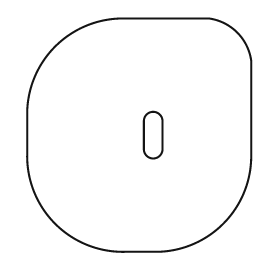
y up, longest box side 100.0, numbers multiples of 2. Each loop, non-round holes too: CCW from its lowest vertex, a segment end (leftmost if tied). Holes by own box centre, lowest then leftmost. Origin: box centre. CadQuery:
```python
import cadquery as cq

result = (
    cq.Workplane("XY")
    .moveTo(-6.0, -50.0)
    .lineTo(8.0, -50.0)
    .threePointArc((36.0, -38.0), (48.0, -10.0))
    .lineTo(48.0, 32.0)
    .threePointArc((42.0, 44.0), (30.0, 50.0))
    .lineTo(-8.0, 50.0)
    .threePointArc((-36.0, 38.0), (-48.0, 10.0))
    .lineTo(-48.0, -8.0)
    .threePointArc((-36.0, -38.0), (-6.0, -50.0))
    .close()
    .moveTo(2.0, -6.0)
    .threePointArc((6.0, -10.0), (10.0, -6.0))
    .lineTo(10.0, 6.0)
    .threePointArc((6.0, 10.0), (2.0, 6.0))
    .close()
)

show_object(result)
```